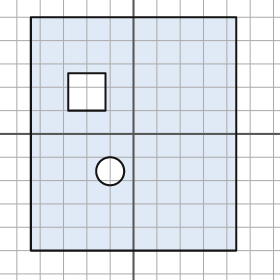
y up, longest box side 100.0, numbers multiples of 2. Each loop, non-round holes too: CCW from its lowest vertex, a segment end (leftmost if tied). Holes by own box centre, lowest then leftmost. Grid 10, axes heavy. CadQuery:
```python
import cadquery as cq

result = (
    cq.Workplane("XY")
    .moveTo(-44.0, -50.0)
    .lineTo(44.0, -50.0)
    .lineTo(44.0, 50.0)
    .lineTo(-44.0, 50.0)
    .close()
    .moveTo(-10.0, -16.0)
    .circle(6.0)
    .moveTo(-28.0, 10.0)
    .lineTo(-12.0, 10.0)
    .lineTo(-12.0, 26.0)
    .lineTo(-28.0, 26.0)
    .close()
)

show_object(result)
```